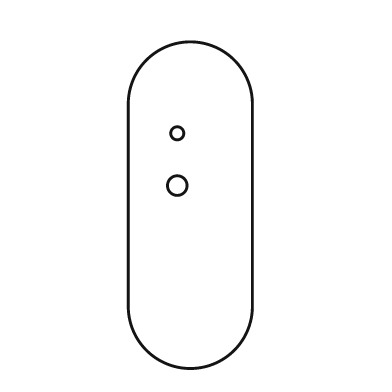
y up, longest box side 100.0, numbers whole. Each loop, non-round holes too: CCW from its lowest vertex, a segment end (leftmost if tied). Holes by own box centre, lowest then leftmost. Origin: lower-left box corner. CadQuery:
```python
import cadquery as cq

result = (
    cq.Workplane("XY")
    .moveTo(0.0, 19.0)
    .threePointArc((19.0, 0.0), (38.0, 19.0))
    .lineTo(38.0, 81.0)
    .threePointArc((19.0, 100.0), (0.0, 81.0))
    .close()
    .moveTo(15.0, 56.0)
    .circle(3.0)
    .moveTo(15.0, 72.0)
    .circle(2.0)
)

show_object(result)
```